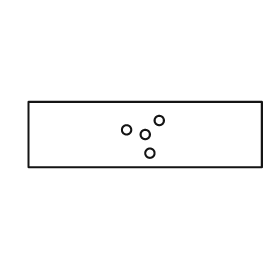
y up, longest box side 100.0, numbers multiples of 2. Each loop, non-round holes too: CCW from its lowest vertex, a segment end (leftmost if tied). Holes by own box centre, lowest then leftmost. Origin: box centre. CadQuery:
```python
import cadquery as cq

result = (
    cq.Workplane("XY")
    .moveTo(-50.0, -14.0)
    .lineTo(50.0, -14.0)
    .lineTo(50.0, 14.0)
    .lineTo(-50.0, 14.0)
    .close()
    .moveTo(2.0, -8.0)
    .circle(2.0)
    .moveTo(0.0, 0.0)
    .circle(2.0)
    .moveTo(-8.0, 2.0)
    .circle(2.0)
    .moveTo(6.0, 6.0)
    .circle(2.0)
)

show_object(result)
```